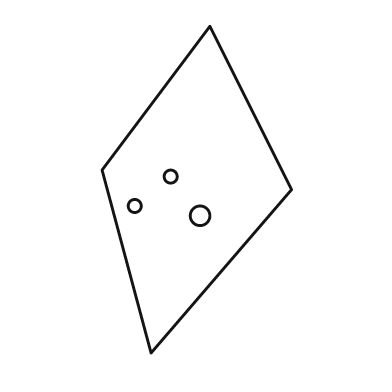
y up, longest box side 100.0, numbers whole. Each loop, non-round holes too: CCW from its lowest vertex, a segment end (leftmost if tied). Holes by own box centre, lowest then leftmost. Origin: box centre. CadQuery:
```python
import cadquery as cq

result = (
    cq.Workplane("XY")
    .moveTo(-14.0, -50.0)
    .lineTo(29.0, 0.0)
    .lineTo(4.0, 50.0)
    .lineTo(-29.0, 6.0)
    .close()
    .moveTo(1.0, -8.0)
    .circle(3.0)
    .moveTo(-19.0, -5.0)
    .circle(2.0)
    .moveTo(-8.0, 4.0)
    .circle(2.0)
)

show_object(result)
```